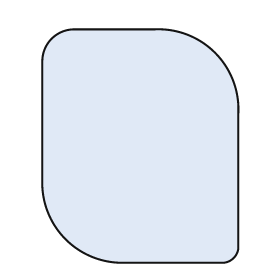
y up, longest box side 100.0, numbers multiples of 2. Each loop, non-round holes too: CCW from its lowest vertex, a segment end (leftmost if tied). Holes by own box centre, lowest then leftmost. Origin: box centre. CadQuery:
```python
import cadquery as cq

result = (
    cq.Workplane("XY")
    .moveTo(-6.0, -50.0)
    .lineTo(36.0, -50.0)
    .threePointArc((40.0, -48.0), (42.0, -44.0))
    .lineTo(42.0, 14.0)
    .threePointArc((32.0, 40.0), (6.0, 50.0))
    .lineTo(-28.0, 50.0)
    .threePointArc((-38.0, 46.0), (-42.0, 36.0))
    .lineTo(-42.0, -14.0)
    .threePointArc((-32.0, -40.0), (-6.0, -50.0))
    .close()
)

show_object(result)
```